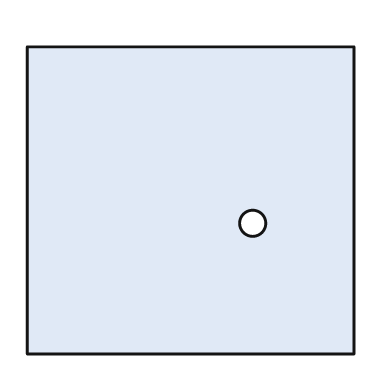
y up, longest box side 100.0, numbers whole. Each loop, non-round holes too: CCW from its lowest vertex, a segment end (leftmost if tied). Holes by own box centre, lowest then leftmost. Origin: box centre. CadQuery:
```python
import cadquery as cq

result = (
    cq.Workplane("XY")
    .moveTo(-50.0, -47.0)
    .lineTo(50.0, -47.0)
    .lineTo(50.0, 47.0)
    .lineTo(-50.0, 47.0)
    .close()
    .moveTo(19.0, -7.0)
    .circle(4.0)
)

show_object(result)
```